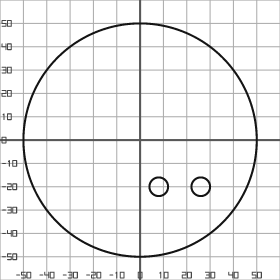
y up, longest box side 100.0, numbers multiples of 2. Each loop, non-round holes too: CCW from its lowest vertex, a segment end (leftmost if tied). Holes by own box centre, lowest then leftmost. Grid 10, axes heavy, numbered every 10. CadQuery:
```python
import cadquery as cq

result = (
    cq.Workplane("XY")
    .moveTo(0.0, 0.0)
    .circle(50.0)
    .moveTo(8.0, -20.0)
    .circle(4.0)
    .moveTo(26.0, -20.0)
    .circle(4.0)
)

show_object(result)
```